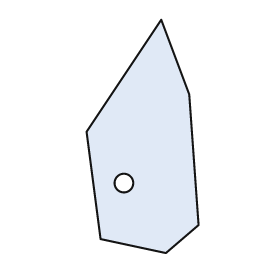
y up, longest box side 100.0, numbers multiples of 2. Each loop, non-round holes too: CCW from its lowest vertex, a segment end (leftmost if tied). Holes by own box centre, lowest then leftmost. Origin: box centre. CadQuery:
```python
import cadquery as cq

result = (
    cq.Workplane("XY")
    .moveTo(10.0, -50.0)
    .lineTo(24.0, -38.0)
    .lineTo(20.0, 18.0)
    .lineTo(8.0, 50.0)
    .lineTo(-24.0, 2.0)
    .lineTo(-18.0, -44.0)
    .close()
    .moveTo(-8.0, -20.0)
    .circle(4.0)
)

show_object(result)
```